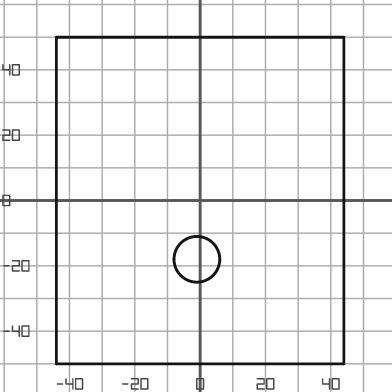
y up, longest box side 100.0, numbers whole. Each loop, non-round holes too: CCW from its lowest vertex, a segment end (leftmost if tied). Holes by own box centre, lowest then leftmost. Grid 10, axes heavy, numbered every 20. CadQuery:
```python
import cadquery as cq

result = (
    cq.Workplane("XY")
    .moveTo(-44.0, -50.0)
    .lineTo(44.0, -50.0)
    .lineTo(44.0, 50.0)
    .lineTo(-44.0, 50.0)
    .close()
    .moveTo(-1.0, -18.0)
    .circle(7.0)
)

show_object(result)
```